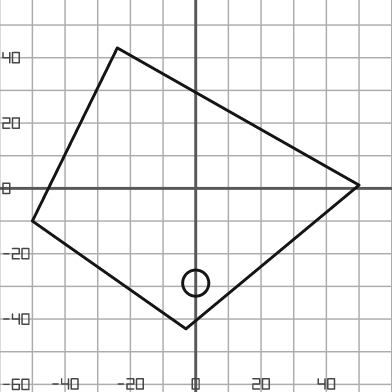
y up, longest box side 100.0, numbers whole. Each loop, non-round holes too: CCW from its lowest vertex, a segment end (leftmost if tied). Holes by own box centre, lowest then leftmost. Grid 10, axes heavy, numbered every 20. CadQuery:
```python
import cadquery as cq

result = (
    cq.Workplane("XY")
    .moveTo(-3.0, -43.0)
    .lineTo(50.0, 1.0)
    .lineTo(-24.0, 43.0)
    .lineTo(-50.0, -10.0)
    .close()
    .moveTo(0.0, -29.0)
    .circle(4.0)
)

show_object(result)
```